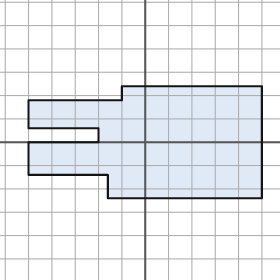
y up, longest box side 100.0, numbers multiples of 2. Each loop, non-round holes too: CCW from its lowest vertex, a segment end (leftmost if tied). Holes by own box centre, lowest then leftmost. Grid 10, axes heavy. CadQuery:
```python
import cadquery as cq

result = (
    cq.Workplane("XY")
    .moveTo(-16.0, -24.0)
    .lineTo(50.0, -24.0)
    .lineTo(50.0, 24.0)
    .lineTo(-10.0, 24.0)
    .lineTo(-10.0, 18.0)
    .lineTo(-50.0, 18.0)
    .lineTo(-50.0, 6.0)
    .lineTo(-20.0, 6.0)
    .lineTo(-20.0, 0.0)
    .lineTo(-50.0, 0.0)
    .lineTo(-50.0, -14.0)
    .lineTo(-16.0, -14.0)
    .close()
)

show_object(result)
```